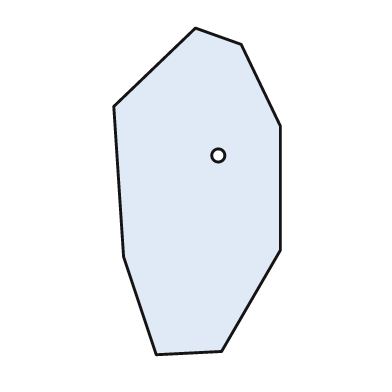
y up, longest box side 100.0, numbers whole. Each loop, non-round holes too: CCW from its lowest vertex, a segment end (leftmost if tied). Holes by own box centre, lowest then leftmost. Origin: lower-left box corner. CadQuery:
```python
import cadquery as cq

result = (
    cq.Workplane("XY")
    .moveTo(13.0, 0.0)
    .lineTo(33.0, 1.0)
    .lineTo(51.0, 32.0)
    .lineTo(51.0, 70.0)
    .lineTo(39.0, 95.0)
    .lineTo(25.0, 100.0)
    .lineTo(0.0, 76.0)
    .lineTo(3.0, 30.0)
    .close()
    .moveTo(32.0, 61.0)
    .circle(2.0)
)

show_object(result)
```